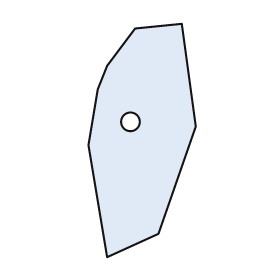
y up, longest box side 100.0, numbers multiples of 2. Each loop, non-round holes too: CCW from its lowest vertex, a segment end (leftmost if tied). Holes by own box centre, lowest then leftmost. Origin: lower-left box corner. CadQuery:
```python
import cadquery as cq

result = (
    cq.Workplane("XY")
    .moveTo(8.0, 0.0)
    .lineTo(30.0, 10.0)
    .lineTo(46.0, 56.0)
    .lineTo(40.0, 100.0)
    .lineTo(20.0, 98.0)
    .lineTo(8.0, 82.0)
    .lineTo(4.0, 72.0)
    .lineTo(0.0, 48.0)
    .close()
    .moveTo(18.0, 58.0)
    .circle(4.0)
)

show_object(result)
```